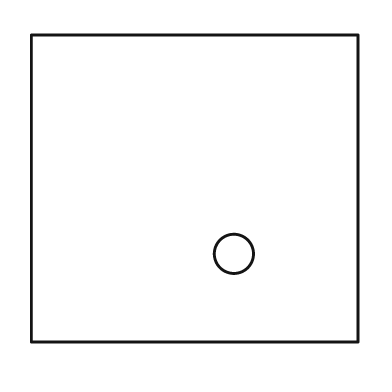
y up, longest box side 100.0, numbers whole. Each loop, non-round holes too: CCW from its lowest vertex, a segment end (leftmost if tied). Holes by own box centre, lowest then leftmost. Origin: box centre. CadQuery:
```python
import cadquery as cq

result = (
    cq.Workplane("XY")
    .moveTo(-50.0, -47.0)
    .lineTo(50.0, -47.0)
    .lineTo(50.0, 47.0)
    .lineTo(-50.0, 47.0)
    .close()
    .moveTo(12.0, -20.0)
    .circle(6.0)
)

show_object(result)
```